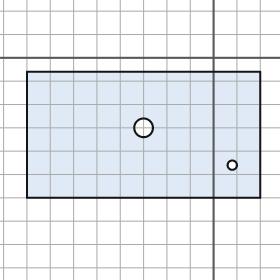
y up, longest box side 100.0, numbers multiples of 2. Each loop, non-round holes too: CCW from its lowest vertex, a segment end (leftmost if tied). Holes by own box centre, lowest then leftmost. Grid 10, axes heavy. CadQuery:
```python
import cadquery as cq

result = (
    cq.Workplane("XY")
    .moveTo(-80.0, -60.0)
    .lineTo(20.0, -60.0)
    .lineTo(20.0, -6.0)
    .lineTo(-80.0, -6.0)
    .close()
    .moveTo(8.0, -46.0)
    .circle(2.0)
    .moveTo(-30.0, -30.0)
    .circle(4.0)
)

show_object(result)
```